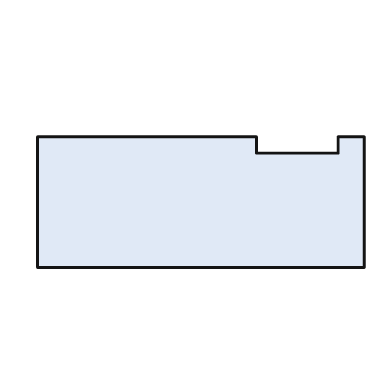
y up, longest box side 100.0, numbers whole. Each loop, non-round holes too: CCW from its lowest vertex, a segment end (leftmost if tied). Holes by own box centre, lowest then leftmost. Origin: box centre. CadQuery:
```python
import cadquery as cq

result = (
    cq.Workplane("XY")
    .moveTo(-50.0, -20.0)
    .lineTo(50.0, -20.0)
    .lineTo(50.0, 20.0)
    .lineTo(42.0, 20.0)
    .lineTo(42.0, 15.0)
    .lineTo(17.0, 15.0)
    .lineTo(17.0, 20.0)
    .lineTo(-50.0, 20.0)
    .close()
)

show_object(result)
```